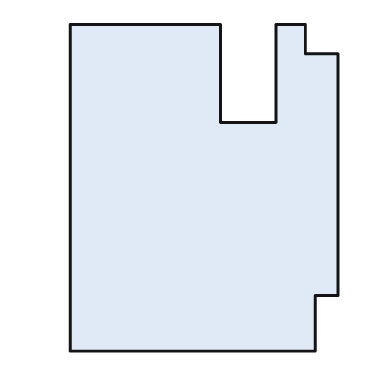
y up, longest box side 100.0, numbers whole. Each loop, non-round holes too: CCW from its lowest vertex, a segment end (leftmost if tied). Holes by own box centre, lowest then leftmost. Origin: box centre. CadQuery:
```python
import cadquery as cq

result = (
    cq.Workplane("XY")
    .moveTo(-41.0, -50.0)
    .lineTo(34.0, -50.0)
    .lineTo(34.0, -33.0)
    .lineTo(41.0, -33.0)
    .lineTo(41.0, 41.0)
    .lineTo(31.0, 41.0)
    .lineTo(31.0, 50.0)
    .lineTo(22.0, 50.0)
    .lineTo(22.0, 20.0)
    .lineTo(5.0, 20.0)
    .lineTo(5.0, 50.0)
    .lineTo(-41.0, 50.0)
    .close()
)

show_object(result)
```